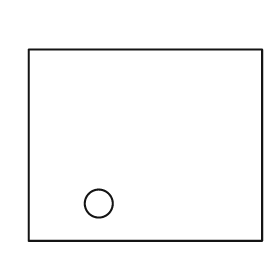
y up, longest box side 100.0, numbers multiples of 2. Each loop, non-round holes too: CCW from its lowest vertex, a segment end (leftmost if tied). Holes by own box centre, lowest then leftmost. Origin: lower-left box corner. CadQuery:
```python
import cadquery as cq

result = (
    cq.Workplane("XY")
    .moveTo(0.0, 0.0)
    .lineTo(100.0, 0.0)
    .lineTo(100.0, 82.0)
    .lineTo(0.0, 82.0)
    .close()
    .moveTo(30.0, 16.0)
    .circle(6.0)
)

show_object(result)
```